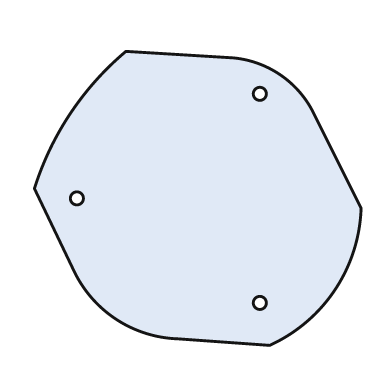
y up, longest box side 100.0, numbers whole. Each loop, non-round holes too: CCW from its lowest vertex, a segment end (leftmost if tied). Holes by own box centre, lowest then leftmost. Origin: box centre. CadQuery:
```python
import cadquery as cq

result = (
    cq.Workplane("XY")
    .moveTo(22.0, -45.0)
    .threePointArc((42.0, -28.0), (50.0, -3.0))
    .lineTo(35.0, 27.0)
    .threePointArc((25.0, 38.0), (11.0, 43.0))
    .lineTo(-22.0, 45.0)
    .threePointArc((-39.0, 26.0), (-50.0, 3.0))
    .lineTo(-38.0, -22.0)
    .threePointArc((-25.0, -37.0), (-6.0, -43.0))
    .close()
    .moveTo(19.0, -32.0)
    .circle(2.0)
    .moveTo(-37.0, 0.0)
    .circle(2.0)
    .moveTo(19.0, 32.0)
    .circle(2.0)
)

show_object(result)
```